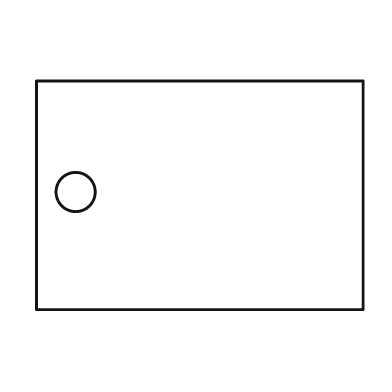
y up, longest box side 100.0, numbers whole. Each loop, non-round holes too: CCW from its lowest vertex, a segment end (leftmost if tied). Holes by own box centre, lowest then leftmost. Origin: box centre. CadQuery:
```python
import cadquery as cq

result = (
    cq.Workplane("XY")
    .moveTo(-50.0, -35.0)
    .lineTo(50.0, -35.0)
    .lineTo(50.0, 35.0)
    .lineTo(-50.0, 35.0)
    .close()
    .moveTo(-38.0, 1.0)
    .circle(6.0)
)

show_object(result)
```